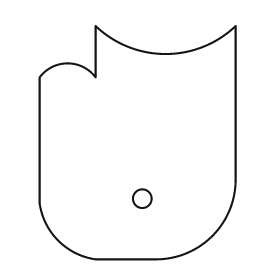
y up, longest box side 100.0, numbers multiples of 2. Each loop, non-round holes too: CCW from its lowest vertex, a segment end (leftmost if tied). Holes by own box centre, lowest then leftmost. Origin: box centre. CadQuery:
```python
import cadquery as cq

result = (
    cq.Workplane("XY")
    .moveTo(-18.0, -50.0)
    .lineTo(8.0, -50.0)
    .threePointArc((32.0, -40.0), (42.0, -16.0))
    .lineTo(42.0, 50.0)
    .threePointArc((12.0, 38.0), (-18.0, 50.0))
    .lineTo(-18.0, 28.0)
    .threePointArc((-30.0, 34.0), (-42.0, 28.0))
    .lineTo(-42.0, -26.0)
    .threePointArc((-34.0, -42.0), (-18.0, -50.0))
    .close()
    .moveTo(2.0, -24.0)
    .circle(4.0)
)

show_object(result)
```